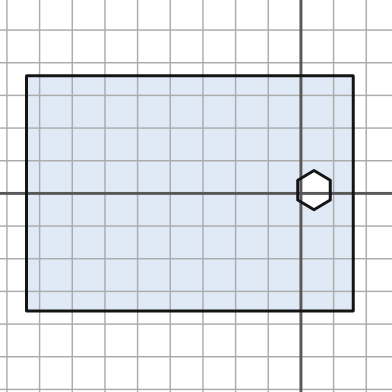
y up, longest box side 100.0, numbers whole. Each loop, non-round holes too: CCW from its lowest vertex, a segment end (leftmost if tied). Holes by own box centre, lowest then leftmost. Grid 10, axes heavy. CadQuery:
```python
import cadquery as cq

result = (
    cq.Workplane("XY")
    .moveTo(-84.0, -36.0)
    .lineTo(16.0, -36.0)
    .lineTo(16.0, 36.0)
    .lineTo(-84.0, 36.0)
    .close()
    .moveTo(4.0, -5.0)
    .lineTo(9.0, -2.0)
    .lineTo(9.0, 4.0)
    .lineTo(4.0, 7.0)
    .lineTo(-1.0, 4.0)
    .lineTo(-1.0, -2.0)
    .close()
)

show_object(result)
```